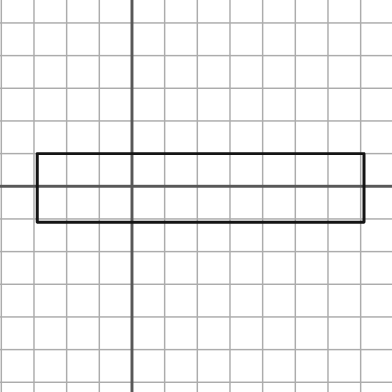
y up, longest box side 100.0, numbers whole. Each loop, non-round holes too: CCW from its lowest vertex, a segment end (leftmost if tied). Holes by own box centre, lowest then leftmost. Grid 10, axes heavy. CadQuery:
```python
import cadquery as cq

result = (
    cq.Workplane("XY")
    .moveTo(-29.0, -11.0)
    .lineTo(71.0, -11.0)
    .lineTo(71.0, 10.0)
    .lineTo(-29.0, 10.0)
    .close()
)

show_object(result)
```